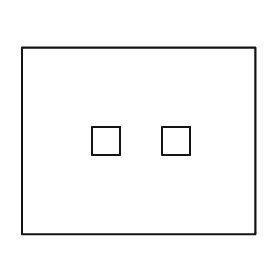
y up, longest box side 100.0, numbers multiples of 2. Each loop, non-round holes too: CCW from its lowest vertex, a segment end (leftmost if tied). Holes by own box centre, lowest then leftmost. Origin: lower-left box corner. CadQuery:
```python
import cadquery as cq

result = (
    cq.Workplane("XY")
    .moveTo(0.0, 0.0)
    .lineTo(100.0, 0.0)
    .lineTo(100.0, 80.0)
    .lineTo(0.0, 80.0)
    .close()
    .moveTo(30.0, 34.0)
    .lineTo(42.0, 34.0)
    .lineTo(42.0, 46.0)
    .lineTo(30.0, 46.0)
    .close()
    .moveTo(60.0, 34.0)
    .lineTo(72.0, 34.0)
    .lineTo(72.0, 46.0)
    .lineTo(60.0, 46.0)
    .close()
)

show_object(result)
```